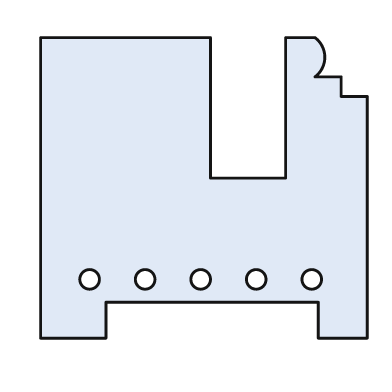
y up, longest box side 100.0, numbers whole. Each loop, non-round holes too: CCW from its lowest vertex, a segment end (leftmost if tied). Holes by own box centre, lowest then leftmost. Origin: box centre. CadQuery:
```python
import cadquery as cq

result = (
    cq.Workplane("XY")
    .moveTo(-50.0, -46.0)
    .lineTo(-30.0, -46.0)
    .lineTo(-30.0, -35.0)
    .lineTo(35.0, -35.0)
    .lineTo(35.0, -46.0)
    .lineTo(50.0, -46.0)
    .lineTo(50.0, 28.0)
    .lineTo(42.0, 28.0)
    .lineTo(42.0, 34.0)
    .lineTo(34.0, 34.0)
    .threePointArc((37.0, 40.0), (34.0, 46.0))
    .lineTo(25.0, 46.0)
    .lineTo(25.0, 3.0)
    .lineTo(2.0, 3.0)
    .lineTo(2.0, 46.0)
    .lineTo(-50.0, 46.0)
    .close()
    .moveTo(-35.0, -28.0)
    .circle(3.0)
    .moveTo(-18.0, -28.0)
    .circle(3.0)
    .moveTo(-1.0, -28.0)
    .circle(3.0)
    .moveTo(16.0, -28.0)
    .circle(3.0)
    .moveTo(33.0, -28.0)
    .circle(3.0)
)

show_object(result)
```